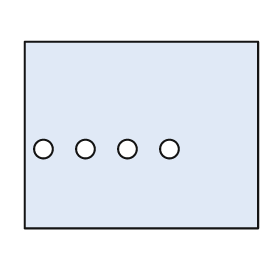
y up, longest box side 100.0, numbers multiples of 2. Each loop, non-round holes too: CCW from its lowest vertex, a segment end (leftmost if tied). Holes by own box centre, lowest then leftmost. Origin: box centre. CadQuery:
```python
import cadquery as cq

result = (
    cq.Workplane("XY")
    .moveTo(-50.0, -40.0)
    .lineTo(50.0, -40.0)
    .lineTo(50.0, 40.0)
    .lineTo(-50.0, 40.0)
    .close()
    .moveTo(-42.0, -6.0)
    .circle(4.0)
    .moveTo(-24.0, -6.0)
    .circle(4.0)
    .moveTo(-6.0, -6.0)
    .circle(4.0)
    .moveTo(12.0, -6.0)
    .circle(4.0)
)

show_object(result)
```